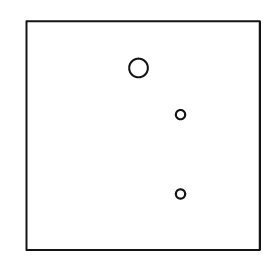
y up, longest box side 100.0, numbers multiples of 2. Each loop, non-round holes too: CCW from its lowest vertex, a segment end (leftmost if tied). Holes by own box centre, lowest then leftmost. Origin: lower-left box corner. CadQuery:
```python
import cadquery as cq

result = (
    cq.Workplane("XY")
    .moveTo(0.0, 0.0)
    .lineTo(100.0, 0.0)
    .lineTo(100.0, 98.0)
    .lineTo(0.0, 98.0)
    .close()
    .moveTo(66.0, 24.0)
    .circle(2.0)
    .moveTo(66.0, 58.0)
    .circle(2.0)
    .moveTo(48.0, 78.0)
    .circle(4.0)
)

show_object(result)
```